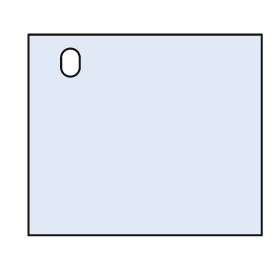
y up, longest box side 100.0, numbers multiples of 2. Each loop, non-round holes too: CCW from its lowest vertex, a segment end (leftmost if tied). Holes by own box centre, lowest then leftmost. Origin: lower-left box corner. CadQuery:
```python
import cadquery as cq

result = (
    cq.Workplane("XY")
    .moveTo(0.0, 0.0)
    .lineTo(100.0, 0.0)
    .lineTo(100.0, 86.0)
    .lineTo(0.0, 86.0)
    .close()
    .moveTo(14.0, 72.0)
    .threePointArc((18.0, 68.0), (22.0, 72.0))
    .lineTo(22.0, 76.0)
    .threePointArc((18.0, 80.0), (14.0, 76.0))
    .close()
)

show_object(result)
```